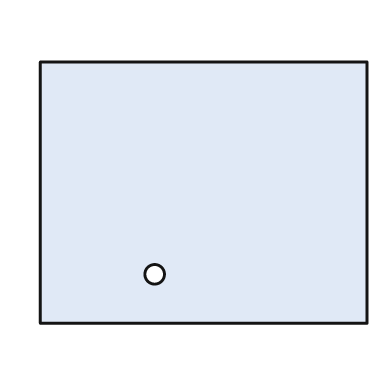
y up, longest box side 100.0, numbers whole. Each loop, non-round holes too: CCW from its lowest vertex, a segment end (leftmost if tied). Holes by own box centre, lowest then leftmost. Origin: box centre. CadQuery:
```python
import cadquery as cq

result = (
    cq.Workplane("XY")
    .moveTo(-50.0, -40.0)
    .lineTo(50.0, -40.0)
    .lineTo(50.0, 40.0)
    .lineTo(-50.0, 40.0)
    .close()
    .moveTo(-15.0, -25.0)
    .circle(3.0)
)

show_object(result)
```